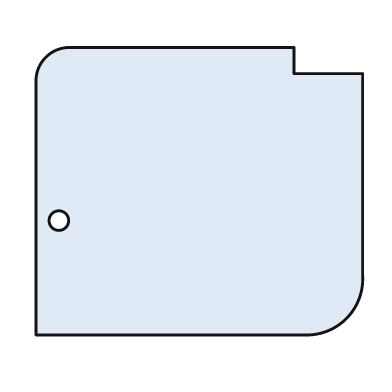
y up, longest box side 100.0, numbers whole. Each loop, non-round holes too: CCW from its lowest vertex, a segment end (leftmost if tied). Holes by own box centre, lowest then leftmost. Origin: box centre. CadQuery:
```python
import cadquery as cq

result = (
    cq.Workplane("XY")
    .moveTo(-50.0, -44.0)
    .lineTo(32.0, -44.0)
    .threePointArc((45.0, -39.0), (50.0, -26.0))
    .lineTo(50.0, 36.0)
    .lineTo(29.0, 36.0)
    .lineTo(29.0, 44.0)
    .lineTo(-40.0, 44.0)
    .threePointArc((-47.0, 41.0), (-50.0, 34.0))
    .close()
    .moveTo(-43.0, -9.0)
    .circle(3.0)
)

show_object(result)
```